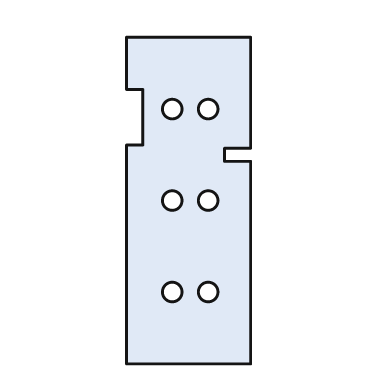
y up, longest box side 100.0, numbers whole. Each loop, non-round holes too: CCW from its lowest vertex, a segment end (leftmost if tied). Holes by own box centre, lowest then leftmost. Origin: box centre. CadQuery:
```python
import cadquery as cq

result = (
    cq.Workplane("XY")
    .moveTo(-19.0, -50.0)
    .lineTo(19.0, -50.0)
    .lineTo(19.0, 12.0)
    .lineTo(11.0, 12.0)
    .lineTo(11.0, 16.0)
    .lineTo(19.0, 16.0)
    .lineTo(19.0, 50.0)
    .lineTo(-19.0, 50.0)
    .lineTo(-19.0, 34.0)
    .lineTo(-14.0, 34.0)
    .lineTo(-14.0, 17.0)
    .lineTo(-19.0, 17.0)
    .close()
    .moveTo(-5.0, -28.0)
    .circle(3.0)
    .moveTo(6.0, -28.0)
    .circle(3.0)
    .moveTo(-5.0, 0.0)
    .circle(3.0)
    .moveTo(6.0, 0.0)
    .circle(3.0)
    .moveTo(-5.0, 28.0)
    .circle(3.0)
    .moveTo(6.0, 28.0)
    .circle(3.0)
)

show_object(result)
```